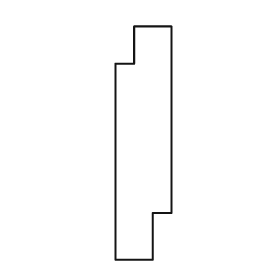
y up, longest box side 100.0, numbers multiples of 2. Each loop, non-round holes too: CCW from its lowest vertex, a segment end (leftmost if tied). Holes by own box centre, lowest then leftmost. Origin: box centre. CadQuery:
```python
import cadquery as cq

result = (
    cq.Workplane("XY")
    .moveTo(-12.0, -50.0)
    .lineTo(4.0, -50.0)
    .lineTo(4.0, -30.0)
    .lineTo(12.0, -30.0)
    .lineTo(12.0, 50.0)
    .lineTo(-4.0, 50.0)
    .lineTo(-4.0, 34.0)
    .lineTo(-12.0, 34.0)
    .close()
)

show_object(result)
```